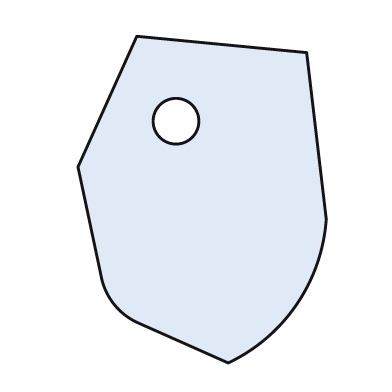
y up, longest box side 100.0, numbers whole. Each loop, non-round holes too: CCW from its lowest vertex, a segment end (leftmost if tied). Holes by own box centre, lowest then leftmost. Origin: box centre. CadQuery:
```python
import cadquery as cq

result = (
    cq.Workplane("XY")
    .moveTo(8.0, -50.0)
    .threePointArc((29.0, -32.0), (38.0, -6.0))
    .lineTo(32.0, 45.0)
    .lineTo(-20.0, 50.0)
    .lineTo(-38.0, 10.0)
    .lineTo(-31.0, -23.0)
    .threePointArc((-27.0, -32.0), (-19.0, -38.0))
    .close()
    .moveTo(-8.0, 24.0)
    .circle(7.0)
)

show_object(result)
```